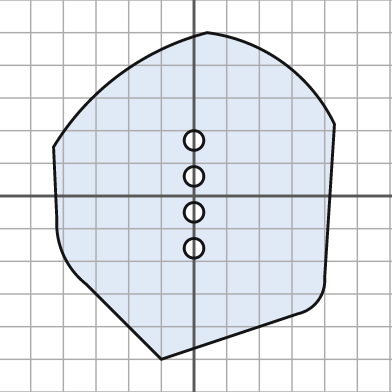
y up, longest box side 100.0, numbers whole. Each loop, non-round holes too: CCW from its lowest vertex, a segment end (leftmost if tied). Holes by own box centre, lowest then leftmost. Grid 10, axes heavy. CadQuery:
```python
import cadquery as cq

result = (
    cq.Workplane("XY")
    .moveTo(-10.0, -50.0)
    .lineTo(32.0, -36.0)
    .threePointArc((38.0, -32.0), (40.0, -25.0))
    .lineTo(43.0, 22.0)
    .threePointArc((27.0, 41.0), (4.0, 50.0))
    .threePointArc((-23.0, 37.0), (-43.0, 15.0))
    .lineTo(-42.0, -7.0)
    .threePointArc((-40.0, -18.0), (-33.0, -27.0))
    .close()
    .moveTo(0.0, -16.0)
    .circle(3.0)
    .moveTo(0.0, -5.0)
    .circle(3.0)
    .moveTo(0.0, 6.0)
    .circle(3.0)
    .moveTo(0.0, 17.0)
    .circle(3.0)
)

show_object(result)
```